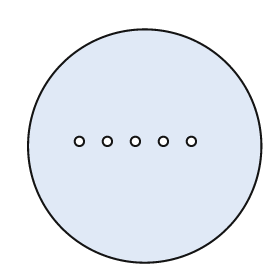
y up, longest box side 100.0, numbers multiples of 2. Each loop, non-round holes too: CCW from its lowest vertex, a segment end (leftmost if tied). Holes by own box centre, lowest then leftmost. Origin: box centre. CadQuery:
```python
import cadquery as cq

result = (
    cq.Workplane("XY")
    .moveTo(0.0, 0.0)
    .circle(50.0)
    .moveTo(-28.0, 2.0)
    .circle(2.0)
    .moveTo(-16.0, 2.0)
    .circle(2.0)
    .moveTo(-4.0, 2.0)
    .circle(2.0)
    .moveTo(8.0, 2.0)
    .circle(2.0)
    .moveTo(20.0, 2.0)
    .circle(2.0)
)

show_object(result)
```